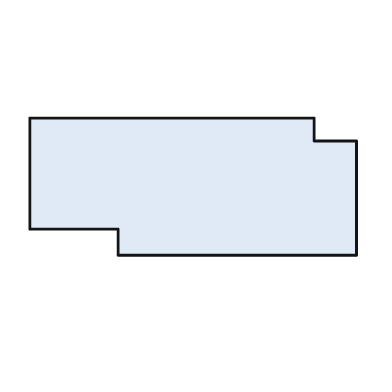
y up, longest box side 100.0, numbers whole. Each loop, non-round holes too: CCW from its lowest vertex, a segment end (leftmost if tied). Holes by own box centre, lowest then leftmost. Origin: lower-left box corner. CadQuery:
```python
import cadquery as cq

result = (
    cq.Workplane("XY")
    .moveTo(27.0, 0.0)
    .lineTo(100.0, 0.0)
    .lineTo(100.0, 35.0)
    .lineTo(87.0, 35.0)
    .lineTo(87.0, 42.0)
    .lineTo(0.0, 42.0)
    .lineTo(0.0, 8.0)
    .lineTo(27.0, 8.0)
    .close()
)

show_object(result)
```